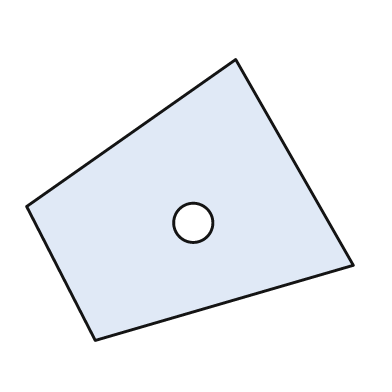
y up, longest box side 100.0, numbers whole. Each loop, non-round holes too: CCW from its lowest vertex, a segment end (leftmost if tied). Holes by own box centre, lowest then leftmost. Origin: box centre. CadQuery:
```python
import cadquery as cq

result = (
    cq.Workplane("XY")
    .moveTo(-29.0, -43.0)
    .lineTo(50.0, -20.0)
    .lineTo(14.0, 43.0)
    .lineTo(-50.0, -2.0)
    .close()
    .moveTo(1.0, -7.0)
    .circle(6.0)
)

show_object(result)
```